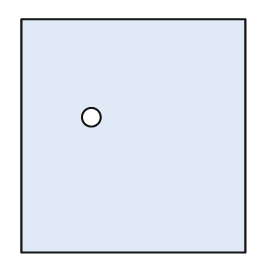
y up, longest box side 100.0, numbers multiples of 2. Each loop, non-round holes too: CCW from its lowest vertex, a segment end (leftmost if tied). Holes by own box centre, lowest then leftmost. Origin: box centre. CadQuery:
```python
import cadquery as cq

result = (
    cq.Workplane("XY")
    .moveTo(-48.0, -50.0)
    .lineTo(48.0, -50.0)
    .lineTo(48.0, 50.0)
    .lineTo(-48.0, 50.0)
    .close()
    .moveTo(-18.0, 8.0)
    .circle(4.0)
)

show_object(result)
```